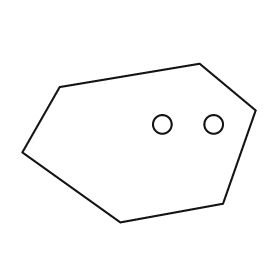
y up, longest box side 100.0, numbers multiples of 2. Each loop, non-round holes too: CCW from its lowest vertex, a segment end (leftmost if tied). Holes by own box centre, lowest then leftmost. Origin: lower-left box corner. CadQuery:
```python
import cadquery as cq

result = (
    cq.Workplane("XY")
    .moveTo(42.0, 0.0)
    .lineTo(86.0, 8.0)
    .lineTo(100.0, 48.0)
    .lineTo(76.0, 68.0)
    .lineTo(16.0, 58.0)
    .lineTo(0.0, 30.0)
    .close()
    .moveTo(60.0, 42.0)
    .circle(4.0)
    .moveTo(82.0, 42.0)
    .circle(4.0)
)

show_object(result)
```